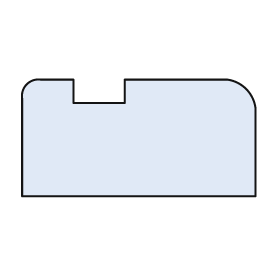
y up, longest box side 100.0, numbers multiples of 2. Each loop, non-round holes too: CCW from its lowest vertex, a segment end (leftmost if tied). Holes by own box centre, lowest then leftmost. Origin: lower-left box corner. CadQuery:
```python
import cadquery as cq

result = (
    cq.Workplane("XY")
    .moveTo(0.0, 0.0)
    .lineTo(100.0, 0.0)
    .lineTo(100.0, 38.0)
    .threePointArc((96.0, 46.0), (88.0, 50.0))
    .lineTo(44.0, 50.0)
    .lineTo(44.0, 40.0)
    .lineTo(22.0, 40.0)
    .lineTo(22.0, 50.0)
    .lineTo(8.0, 50.0)
    .threePointArc((2.0, 48.0), (0.0, 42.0))
    .close()
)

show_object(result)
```